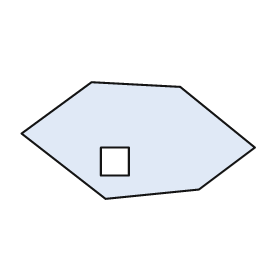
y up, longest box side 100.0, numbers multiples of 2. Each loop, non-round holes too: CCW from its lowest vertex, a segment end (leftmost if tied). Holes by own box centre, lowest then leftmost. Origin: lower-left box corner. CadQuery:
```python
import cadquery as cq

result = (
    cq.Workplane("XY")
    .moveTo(36.0, 0.0)
    .lineTo(76.0, 4.0)
    .lineTo(100.0, 22.0)
    .lineTo(68.0, 48.0)
    .lineTo(30.0, 50.0)
    .lineTo(0.0, 28.0)
    .close()
    .moveTo(34.0, 10.0)
    .lineTo(46.0, 10.0)
    .lineTo(46.0, 22.0)
    .lineTo(34.0, 22.0)
    .close()
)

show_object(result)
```